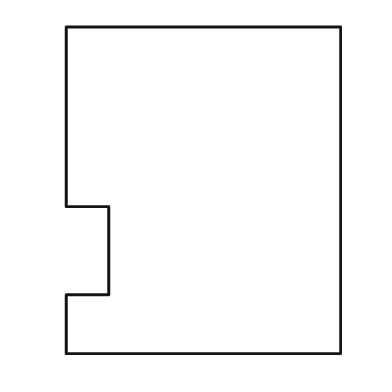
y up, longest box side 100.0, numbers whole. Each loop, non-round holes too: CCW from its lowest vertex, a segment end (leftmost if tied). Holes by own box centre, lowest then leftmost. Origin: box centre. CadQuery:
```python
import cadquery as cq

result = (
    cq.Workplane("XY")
    .moveTo(-42.0, -50.0)
    .lineTo(42.0, -50.0)
    .lineTo(42.0, 50.0)
    .lineTo(-42.0, 50.0)
    .lineTo(-42.0, -5.0)
    .lineTo(-29.0, -5.0)
    .lineTo(-29.0, -32.0)
    .lineTo(-42.0, -32.0)
    .close()
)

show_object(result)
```